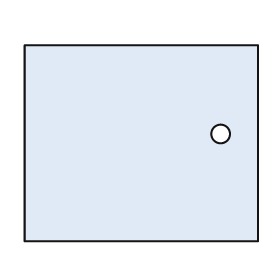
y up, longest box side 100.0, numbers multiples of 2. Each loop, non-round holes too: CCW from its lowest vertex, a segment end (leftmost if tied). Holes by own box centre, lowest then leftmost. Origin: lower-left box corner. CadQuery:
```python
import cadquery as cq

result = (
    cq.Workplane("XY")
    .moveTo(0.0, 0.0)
    .lineTo(100.0, 0.0)
    .lineTo(100.0, 84.0)
    .lineTo(0.0, 84.0)
    .close()
    .moveTo(84.0, 46.0)
    .circle(4.0)
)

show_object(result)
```